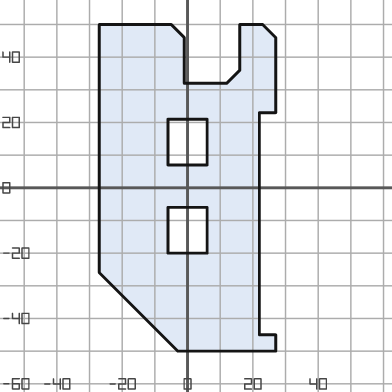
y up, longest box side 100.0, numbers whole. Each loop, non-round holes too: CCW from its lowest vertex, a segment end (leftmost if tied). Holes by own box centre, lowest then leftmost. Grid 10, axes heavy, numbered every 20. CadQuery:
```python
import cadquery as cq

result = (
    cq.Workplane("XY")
    .moveTo(-3.0, -50.0)
    .lineTo(27.0, -50.0)
    .lineTo(27.0, -45.0)
    .lineTo(22.0, -45.0)
    .lineTo(22.0, 23.0)
    .lineTo(27.0, 23.0)
    .lineTo(27.0, 46.0)
    .lineTo(23.0, 50.0)
    .lineTo(16.0, 50.0)
    .lineTo(16.0, 36.0)
    .lineTo(12.0, 32.0)
    .lineTo(-1.0, 32.0)
    .lineTo(-1.0, 46.0)
    .lineTo(-5.0, 50.0)
    .lineTo(-27.0, 50.0)
    .lineTo(-27.0, -26.0)
    .close()
    .moveTo(-6.0, -20.0)
    .lineTo(6.0, -20.0)
    .lineTo(6.0, -6.0)
    .lineTo(-6.0, -6.0)
    .close()
    .moveTo(-6.0, 7.0)
    .lineTo(6.0, 7.0)
    .lineTo(6.0, 21.0)
    .lineTo(-6.0, 21.0)
    .close()
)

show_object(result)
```